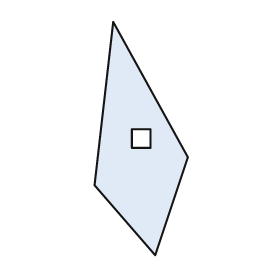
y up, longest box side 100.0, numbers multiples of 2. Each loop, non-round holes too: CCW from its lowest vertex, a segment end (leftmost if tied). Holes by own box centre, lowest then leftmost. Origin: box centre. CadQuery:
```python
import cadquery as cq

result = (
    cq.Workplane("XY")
    .moveTo(6.0, -50.0)
    .lineTo(20.0, -8.0)
    .lineTo(-12.0, 50.0)
    .lineTo(-20.0, -20.0)
    .close()
    .moveTo(-4.0, -4.0)
    .lineTo(4.0, -4.0)
    .lineTo(4.0, 4.0)
    .lineTo(-4.0, 4.0)
    .close()
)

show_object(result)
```